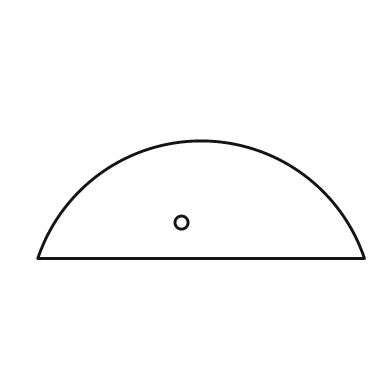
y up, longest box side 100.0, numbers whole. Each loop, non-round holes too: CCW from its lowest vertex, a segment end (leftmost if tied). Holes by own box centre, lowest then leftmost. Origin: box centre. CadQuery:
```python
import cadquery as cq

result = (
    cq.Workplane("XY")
    .moveTo(-50.0, -18.0)
    .lineTo(50.0, -18.0)
    .threePointArc((0.0, 18.0), (-50.0, -18.0))
    .close()
    .moveTo(-6.0, -7.0)
    .circle(2.0)
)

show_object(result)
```